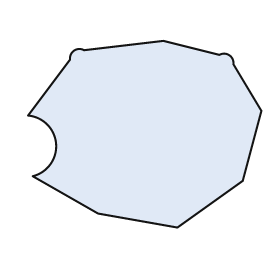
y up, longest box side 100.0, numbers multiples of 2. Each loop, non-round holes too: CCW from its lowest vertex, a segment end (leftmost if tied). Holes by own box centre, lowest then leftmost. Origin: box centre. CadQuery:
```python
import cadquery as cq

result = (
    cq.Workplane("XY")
    .moveTo(14.0, -40.0)
    .lineTo(42.0, -20.0)
    .lineTo(50.0, 10.0)
    .lineTo(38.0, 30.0)
    .threePointArc((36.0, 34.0), (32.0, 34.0))
    .lineTo(8.0, 40.0)
    .lineTo(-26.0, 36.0)
    .threePointArc((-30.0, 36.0), (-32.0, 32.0))
    .lineTo(-50.0, 8.0)
    .threePointArc((-38.0, -4.0), (-48.0, -18.0))
    .lineTo(-20.0, -34.0)
    .close()
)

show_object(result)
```